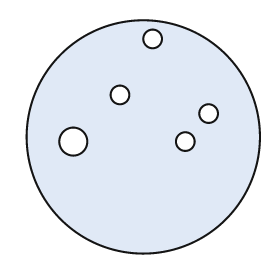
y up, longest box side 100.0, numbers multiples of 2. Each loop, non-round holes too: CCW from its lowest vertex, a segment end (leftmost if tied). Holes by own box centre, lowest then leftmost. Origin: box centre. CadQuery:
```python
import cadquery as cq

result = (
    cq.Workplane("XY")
    .moveTo(0.0, 0.0)
    .circle(50.0)
    .moveTo(-30.0, -2.0)
    .circle(6.0)
    .moveTo(18.0, -2.0)
    .circle(4.0)
    .moveTo(28.0, 10.0)
    .circle(4.0)
    .moveTo(-10.0, 18.0)
    .circle(4.0)
    .moveTo(4.0, 42.0)
    .circle(4.0)
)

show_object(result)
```